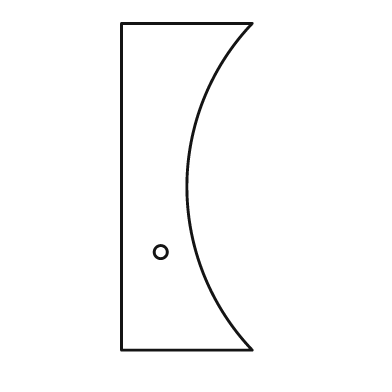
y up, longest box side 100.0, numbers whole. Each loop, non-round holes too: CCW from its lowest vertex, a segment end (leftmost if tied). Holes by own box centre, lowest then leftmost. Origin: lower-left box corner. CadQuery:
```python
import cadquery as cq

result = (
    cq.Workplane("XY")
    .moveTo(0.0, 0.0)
    .lineTo(40.0, 0.0)
    .threePointArc((20.0, 50.0), (40.0, 100.0))
    .lineTo(0.0, 100.0)
    .close()
    .moveTo(12.0, 30.0)
    .circle(2.0)
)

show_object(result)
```